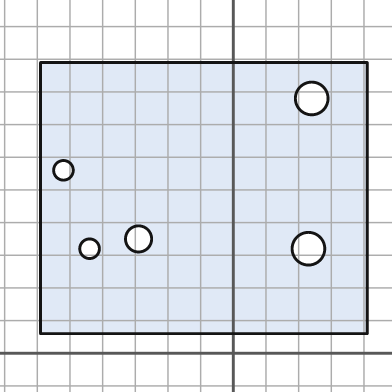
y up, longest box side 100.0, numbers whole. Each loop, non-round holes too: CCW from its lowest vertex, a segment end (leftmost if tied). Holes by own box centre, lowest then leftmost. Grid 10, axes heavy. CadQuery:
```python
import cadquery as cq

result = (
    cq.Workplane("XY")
    .moveTo(-59.0, 6.0)
    .lineTo(41.0, 6.0)
    .lineTo(41.0, 89.0)
    .lineTo(-59.0, 89.0)
    .close()
    .moveTo(-44.0, 32.0)
    .circle(3.0)
    .moveTo(23.0, 32.0)
    .circle(5.0)
    .moveTo(-29.0, 35.0)
    .circle(4.0)
    .moveTo(-52.0, 56.0)
    .circle(3.0)
    .moveTo(24.0, 78.0)
    .circle(5.0)
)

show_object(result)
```